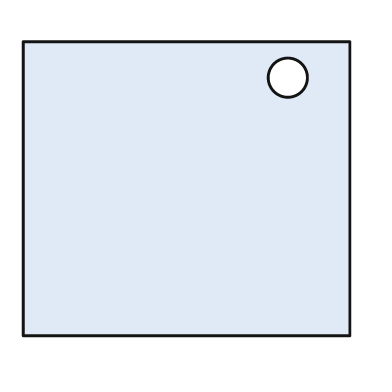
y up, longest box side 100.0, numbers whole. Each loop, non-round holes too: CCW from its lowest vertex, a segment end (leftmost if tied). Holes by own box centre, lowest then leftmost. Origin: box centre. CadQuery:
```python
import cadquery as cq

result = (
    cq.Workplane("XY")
    .moveTo(-50.0, -45.0)
    .lineTo(50.0, -45.0)
    .lineTo(50.0, 45.0)
    .lineTo(-50.0, 45.0)
    .close()
    .moveTo(31.0, 34.0)
    .circle(6.0)
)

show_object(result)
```